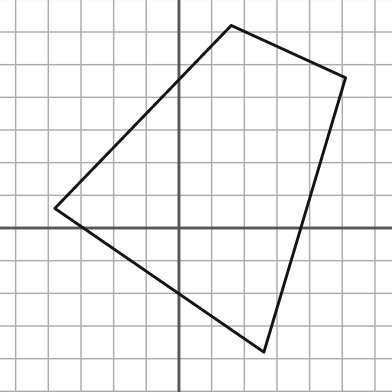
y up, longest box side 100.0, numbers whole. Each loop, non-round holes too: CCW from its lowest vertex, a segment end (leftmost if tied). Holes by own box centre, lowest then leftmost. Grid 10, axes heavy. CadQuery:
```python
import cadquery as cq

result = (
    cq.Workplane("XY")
    .moveTo(26.0, -38.0)
    .lineTo(51.0, 46.0)
    .lineTo(16.0, 62.0)
    .lineTo(-38.0, 6.0)
    .close()
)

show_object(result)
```